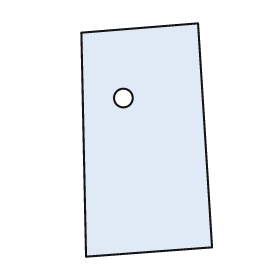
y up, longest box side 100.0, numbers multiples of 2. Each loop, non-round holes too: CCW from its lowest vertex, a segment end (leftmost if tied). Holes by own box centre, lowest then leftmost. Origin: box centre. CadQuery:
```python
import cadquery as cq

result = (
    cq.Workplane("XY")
    .moveTo(-26.0, -50.0)
    .lineTo(28.0, -46.0)
    .lineTo(22.0, 50.0)
    .lineTo(-28.0, 46.0)
    .close()
    .moveTo(-10.0, 18.0)
    .circle(4.0)
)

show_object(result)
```